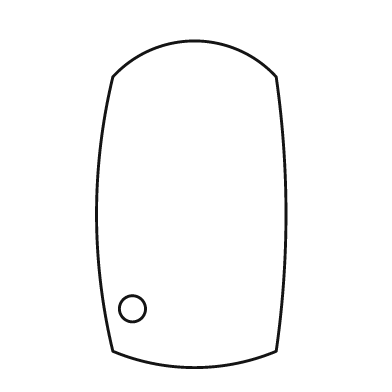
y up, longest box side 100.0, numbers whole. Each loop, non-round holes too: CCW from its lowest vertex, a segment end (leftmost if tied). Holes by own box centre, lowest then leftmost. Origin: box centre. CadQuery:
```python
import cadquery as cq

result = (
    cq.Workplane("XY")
    .moveTo(-24.0, -45.0)
    .threePointArc((1.0, -50.0), (26.0, -45.0))
    .threePointArc((29.0, -3.0), (26.0, 39.0))
    .threePointArc((1.0, 50.0), (-24.0, 39.0))
    .threePointArc((-29.0, -3.0), (-24.0, -45.0))
    .close()
    .moveTo(-18.0, -32.0)
    .circle(4.0)
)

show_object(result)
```